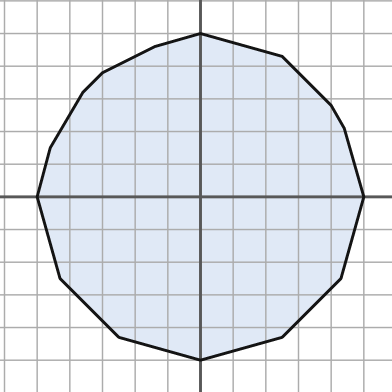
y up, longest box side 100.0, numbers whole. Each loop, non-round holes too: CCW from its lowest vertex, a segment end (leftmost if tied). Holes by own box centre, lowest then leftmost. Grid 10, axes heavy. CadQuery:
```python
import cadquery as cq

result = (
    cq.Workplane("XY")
    .moveTo(0.0, -50.0)
    .lineTo(25.0, -43.0)
    .lineTo(43.0, -25.0)
    .lineTo(50.0, 0.0)
    .lineTo(44.0, 21.0)
    .lineTo(40.0, 28.0)
    .lineTo(25.0, 43.0)
    .lineTo(0.0, 50.0)
    .lineTo(-14.0, 46.0)
    .lineTo(-30.0, 38.0)
    .lineTo(-36.0, 32.0)
    .lineTo(-46.0, 15.0)
    .lineTo(-50.0, 0.0)
    .lineTo(-43.0, -25.0)
    .lineTo(-25.0, -43.0)
    .close()
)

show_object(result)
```